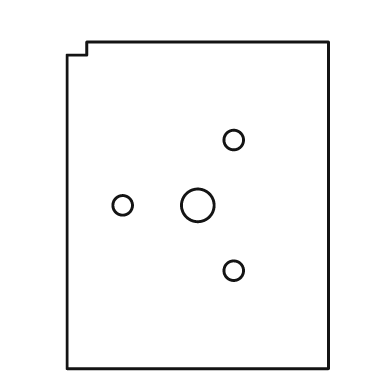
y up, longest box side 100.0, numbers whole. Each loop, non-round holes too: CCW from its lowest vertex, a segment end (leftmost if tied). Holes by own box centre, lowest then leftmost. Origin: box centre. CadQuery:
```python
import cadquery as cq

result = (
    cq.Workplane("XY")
    .moveTo(-40.0, -50.0)
    .lineTo(40.0, -50.0)
    .lineTo(40.0, 50.0)
    .lineTo(-34.0, 50.0)
    .lineTo(-34.0, 46.0)
    .lineTo(-40.0, 46.0)
    .close()
    .moveTo(11.0, -20.0)
    .circle(3.0)
    .moveTo(-23.0, 0.0)
    .circle(3.0)
    .moveTo(0.0, 0.0)
    .circle(5.0)
    .moveTo(11.0, 20.0)
    .circle(3.0)
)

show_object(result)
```